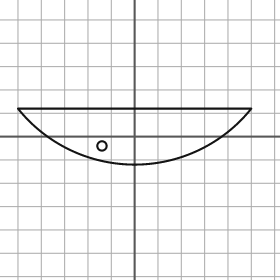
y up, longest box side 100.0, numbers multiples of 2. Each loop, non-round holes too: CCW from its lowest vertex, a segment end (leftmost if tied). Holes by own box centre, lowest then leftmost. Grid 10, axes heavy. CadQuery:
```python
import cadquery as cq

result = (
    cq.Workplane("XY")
    .moveTo(-50.0, 12.0)
    .threePointArc((0.0, -12.0), (50.0, 12.0))
    .close()
    .moveTo(-14.0, -4.0)
    .circle(2.0)
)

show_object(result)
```